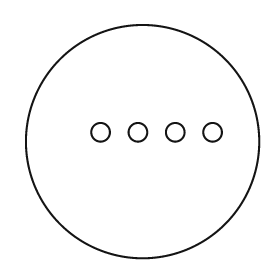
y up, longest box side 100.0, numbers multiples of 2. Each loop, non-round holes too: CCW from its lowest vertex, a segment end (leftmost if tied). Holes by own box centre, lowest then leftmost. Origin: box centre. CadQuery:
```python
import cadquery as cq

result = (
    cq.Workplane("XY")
    .moveTo(0.0, 0.0)
    .circle(50.0)
    .moveTo(-18.0, 4.0)
    .circle(4.0)
    .moveTo(-2.0, 4.0)
    .circle(4.0)
    .moveTo(14.0, 4.0)
    .circle(4.0)
    .moveTo(30.0, 4.0)
    .circle(4.0)
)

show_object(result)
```